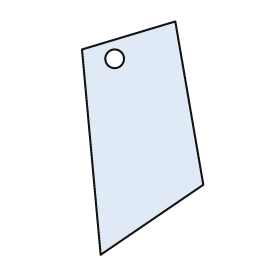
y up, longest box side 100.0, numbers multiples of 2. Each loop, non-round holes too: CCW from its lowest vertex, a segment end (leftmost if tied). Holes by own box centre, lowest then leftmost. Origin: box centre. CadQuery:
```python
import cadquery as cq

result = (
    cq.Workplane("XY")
    .moveTo(-18.0, -50.0)
    .lineTo(26.0, -20.0)
    .lineTo(14.0, 50.0)
    .lineTo(-26.0, 38.0)
    .close()
    .moveTo(-12.0, 34.0)
    .circle(4.0)
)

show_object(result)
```